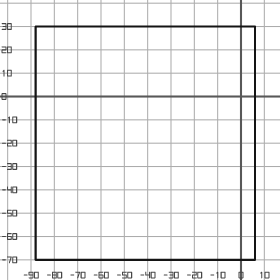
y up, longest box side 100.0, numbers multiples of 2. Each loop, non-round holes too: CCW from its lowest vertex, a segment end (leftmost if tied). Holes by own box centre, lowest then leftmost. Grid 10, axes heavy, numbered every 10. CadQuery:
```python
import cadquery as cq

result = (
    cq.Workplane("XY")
    .moveTo(-88.0, -70.0)
    .lineTo(6.0, -70.0)
    .lineTo(6.0, 30.0)
    .lineTo(-88.0, 30.0)
    .close()
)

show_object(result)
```